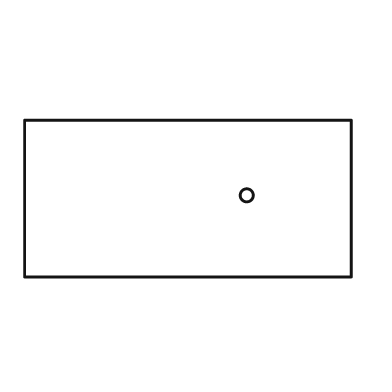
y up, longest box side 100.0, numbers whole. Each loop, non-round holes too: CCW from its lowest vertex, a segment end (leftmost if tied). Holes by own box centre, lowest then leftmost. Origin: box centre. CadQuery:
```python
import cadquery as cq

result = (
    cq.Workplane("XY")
    .moveTo(-50.0, -24.0)
    .lineTo(50.0, -24.0)
    .lineTo(50.0, 24.0)
    .lineTo(-50.0, 24.0)
    .close()
    .moveTo(18.0, 1.0)
    .circle(2.0)
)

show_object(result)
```